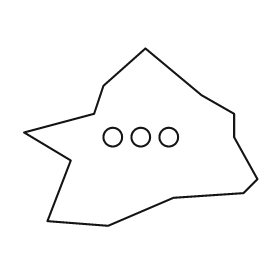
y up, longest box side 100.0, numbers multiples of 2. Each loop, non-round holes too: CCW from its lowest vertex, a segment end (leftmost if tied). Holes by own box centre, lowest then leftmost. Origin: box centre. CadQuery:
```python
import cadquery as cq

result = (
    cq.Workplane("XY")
    .moveTo(-14.0, -38.0)
    .lineTo(14.0, -26.0)
    .lineTo(44.0, -24.0)
    .lineTo(50.0, -18.0)
    .lineTo(40.0, 0.0)
    .lineTo(40.0, 10.0)
    .lineTo(26.0, 18.0)
    .lineTo(2.0, 38.0)
    .lineTo(-16.0, 22.0)
    .lineTo(-20.0, 10.0)
    .lineTo(-50.0, 2.0)
    .lineTo(-30.0, -10.0)
    .lineTo(-40.0, -36.0)
    .close()
    .moveTo(-12.0, 0.0)
    .circle(4.0)
    .moveTo(0.0, 0.0)
    .circle(4.0)
    .moveTo(12.0, 0.0)
    .circle(4.0)
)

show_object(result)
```